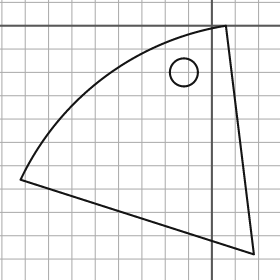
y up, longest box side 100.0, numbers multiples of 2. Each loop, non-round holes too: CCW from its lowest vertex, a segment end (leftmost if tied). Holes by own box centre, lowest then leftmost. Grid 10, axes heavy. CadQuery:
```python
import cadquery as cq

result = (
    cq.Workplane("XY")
    .moveTo(18.0, -98.0)
    .lineTo(6.0, 0.0)
    .threePointArc((-46.0, -22.0), (-82.0, -66.0))
    .close()
    .moveTo(-12.0, -20.0)
    .circle(6.0)
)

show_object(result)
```